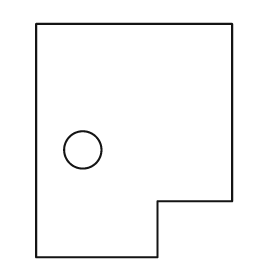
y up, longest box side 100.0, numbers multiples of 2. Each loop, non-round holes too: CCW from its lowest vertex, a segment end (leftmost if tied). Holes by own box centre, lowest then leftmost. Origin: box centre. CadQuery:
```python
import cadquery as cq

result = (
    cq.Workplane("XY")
    .moveTo(-42.0, -50.0)
    .lineTo(10.0, -50.0)
    .lineTo(10.0, -26.0)
    .lineTo(42.0, -26.0)
    .lineTo(42.0, 50.0)
    .lineTo(-42.0, 50.0)
    .close()
    .moveTo(-22.0, -4.0)
    .circle(8.0)
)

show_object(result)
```